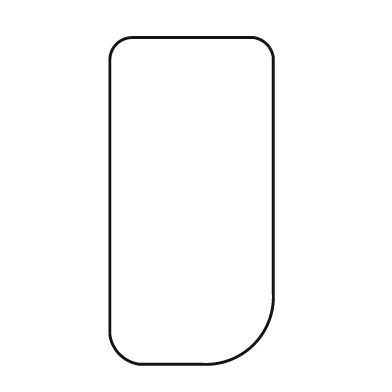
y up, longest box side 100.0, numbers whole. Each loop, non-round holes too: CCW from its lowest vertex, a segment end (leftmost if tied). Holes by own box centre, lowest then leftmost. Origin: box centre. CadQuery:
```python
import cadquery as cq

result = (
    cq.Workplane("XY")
    .moveTo(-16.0, -50.0)
    .lineTo(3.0, -50.0)
    .threePointArc((19.0, -44.0), (25.0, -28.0))
    .lineTo(25.0, 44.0)
    .threePointArc((23.0, 48.0), (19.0, 50.0))
    .lineTo(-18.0, 50.0)
    .threePointArc((-23.0, 48.0), (-25.0, 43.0))
    .lineTo(-25.0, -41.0)
    .threePointArc((-22.0, -47.0), (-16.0, -50.0))
    .close()
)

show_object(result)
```